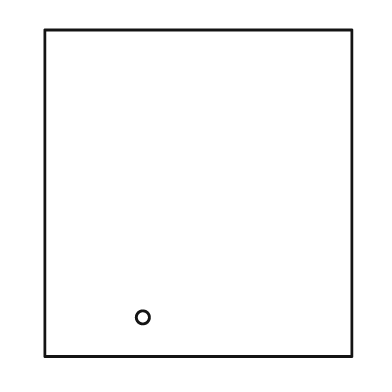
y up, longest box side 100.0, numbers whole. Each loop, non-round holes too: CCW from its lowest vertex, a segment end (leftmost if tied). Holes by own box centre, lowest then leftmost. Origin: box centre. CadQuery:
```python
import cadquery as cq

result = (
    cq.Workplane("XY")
    .moveTo(-47.0, -50.0)
    .lineTo(47.0, -50.0)
    .lineTo(47.0, 50.0)
    .lineTo(-47.0, 50.0)
    .close()
    .moveTo(-17.0, -38.0)
    .circle(2.0)
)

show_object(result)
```